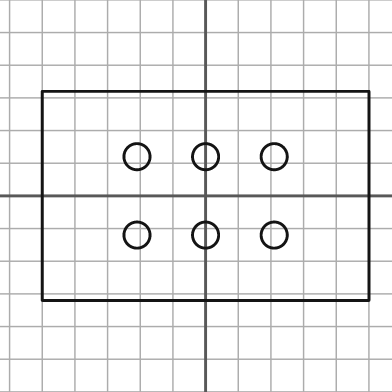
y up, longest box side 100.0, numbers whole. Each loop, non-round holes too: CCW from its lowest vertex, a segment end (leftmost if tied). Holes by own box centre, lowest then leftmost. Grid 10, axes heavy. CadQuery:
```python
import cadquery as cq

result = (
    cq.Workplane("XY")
    .moveTo(-50.0, -32.0)
    .lineTo(50.0, -32.0)
    .lineTo(50.0, 32.0)
    .lineTo(-50.0, 32.0)
    .close()
    .moveTo(-21.0, -12.0)
    .circle(4.0)
    .moveTo(0.0, -12.0)
    .circle(4.0)
    .moveTo(21.0, -12.0)
    .circle(4.0)
    .moveTo(-21.0, 12.0)
    .circle(4.0)
    .moveTo(0.0, 12.0)
    .circle(4.0)
    .moveTo(21.0, 12.0)
    .circle(4.0)
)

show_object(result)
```